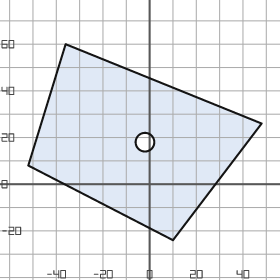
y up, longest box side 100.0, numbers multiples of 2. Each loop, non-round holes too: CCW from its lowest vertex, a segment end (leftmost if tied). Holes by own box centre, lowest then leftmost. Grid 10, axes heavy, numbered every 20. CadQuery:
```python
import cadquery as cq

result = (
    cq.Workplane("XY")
    .moveTo(10.0, -24.0)
    .lineTo(48.0, 26.0)
    .lineTo(-36.0, 60.0)
    .lineTo(-52.0, 8.0)
    .close()
    .moveTo(-2.0, 18.0)
    .circle(4.0)
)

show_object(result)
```